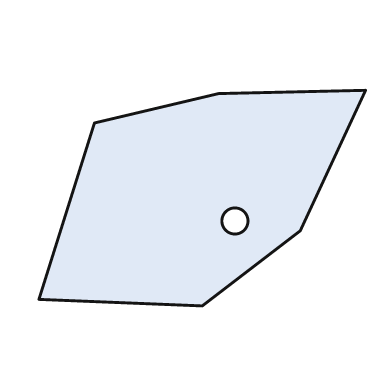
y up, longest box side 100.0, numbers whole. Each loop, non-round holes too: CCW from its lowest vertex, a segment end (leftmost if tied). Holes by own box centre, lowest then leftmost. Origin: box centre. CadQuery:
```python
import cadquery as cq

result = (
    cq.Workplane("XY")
    .moveTo(0.0, -33.0)
    .lineTo(30.0, -10.0)
    .lineTo(50.0, 33.0)
    .lineTo(5.0, 32.0)
    .lineTo(-33.0, 23.0)
    .lineTo(-50.0, -31.0)
    .close()
    .moveTo(10.0, -7.0)
    .circle(4.0)
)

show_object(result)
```